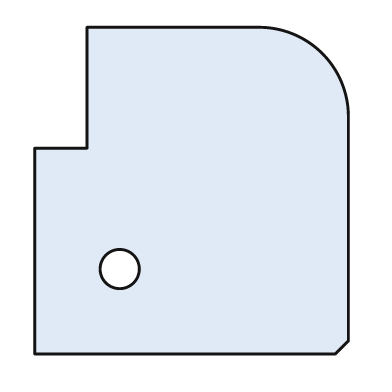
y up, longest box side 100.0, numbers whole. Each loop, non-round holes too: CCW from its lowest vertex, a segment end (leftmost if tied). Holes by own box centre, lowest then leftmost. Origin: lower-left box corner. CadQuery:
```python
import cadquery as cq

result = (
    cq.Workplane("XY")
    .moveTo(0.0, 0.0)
    .lineTo(92.0, 0.0)
    .lineTo(96.0, 4.0)
    .lineTo(96.0, 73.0)
    .threePointArc((88.0, 92.0), (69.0, 100.0))
    .lineTo(16.0, 100.0)
    .lineTo(16.0, 63.0)
    .lineTo(0.0, 63.0)
    .close()
    .moveTo(26.0, 26.0)
    .circle(6.0)
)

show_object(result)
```